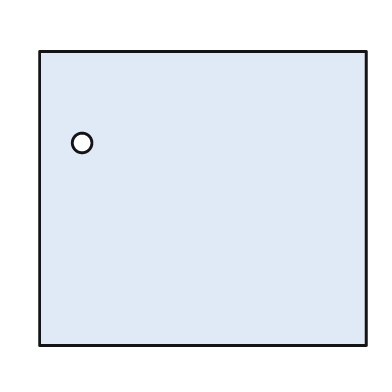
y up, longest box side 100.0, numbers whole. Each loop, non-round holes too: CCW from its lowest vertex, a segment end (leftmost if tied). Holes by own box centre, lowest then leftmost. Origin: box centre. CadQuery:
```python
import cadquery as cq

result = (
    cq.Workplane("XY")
    .moveTo(-50.0, -45.0)
    .lineTo(50.0, -45.0)
    .lineTo(50.0, 45.0)
    .lineTo(-50.0, 45.0)
    .close()
    .moveTo(-37.0, 17.0)
    .circle(3.0)
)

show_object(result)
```